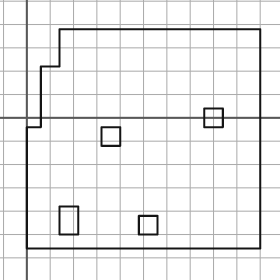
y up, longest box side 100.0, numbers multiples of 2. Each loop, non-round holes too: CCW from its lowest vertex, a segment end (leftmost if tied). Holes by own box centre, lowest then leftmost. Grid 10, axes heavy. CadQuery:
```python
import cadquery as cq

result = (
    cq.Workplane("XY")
    .moveTo(0.0, -56.0)
    .lineTo(100.0, -56.0)
    .lineTo(100.0, 38.0)
    .lineTo(14.0, 38.0)
    .lineTo(14.0, 22.0)
    .lineTo(6.0, 22.0)
    .lineTo(6.0, -4.0)
    .lineTo(0.0, -4.0)
    .close()
    .moveTo(48.0, -50.0)
    .lineTo(56.0, -50.0)
    .lineTo(56.0, -42.0)
    .lineTo(48.0, -42.0)
    .close()
    .moveTo(14.0, -50.0)
    .lineTo(22.0, -50.0)
    .lineTo(22.0, -38.0)
    .lineTo(14.0, -38.0)
    .close()
    .moveTo(32.0, -12.0)
    .lineTo(40.0, -12.0)
    .lineTo(40.0, -4.0)
    .lineTo(32.0, -4.0)
    .close()
    .moveTo(76.0, -4.0)
    .lineTo(84.0, -4.0)
    .lineTo(84.0, 4.0)
    .lineTo(76.0, 4.0)
    .close()
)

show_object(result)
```